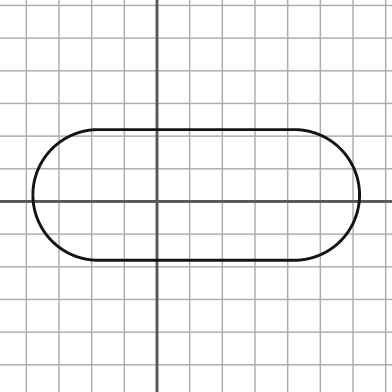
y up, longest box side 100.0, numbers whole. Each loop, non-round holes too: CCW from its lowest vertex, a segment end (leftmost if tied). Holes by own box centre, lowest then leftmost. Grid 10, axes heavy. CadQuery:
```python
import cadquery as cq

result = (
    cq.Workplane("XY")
    .moveTo(-18.0, -18.0)
    .lineTo(42.0, -18.0)
    .threePointArc((62.0, 2.0), (42.0, 22.0))
    .lineTo(-18.0, 22.0)
    .threePointArc((-38.0, 2.0), (-18.0, -18.0))
    .close()
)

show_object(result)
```